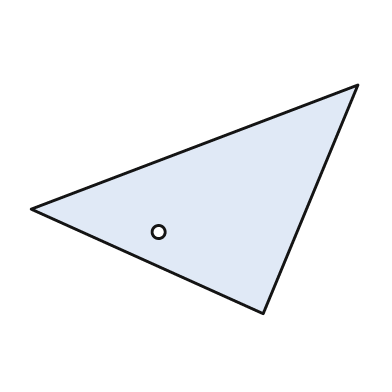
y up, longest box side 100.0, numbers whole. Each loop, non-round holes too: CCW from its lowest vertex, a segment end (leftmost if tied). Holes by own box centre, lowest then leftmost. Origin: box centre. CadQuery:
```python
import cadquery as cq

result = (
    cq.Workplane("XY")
    .moveTo(21.0, -35.0)
    .lineTo(50.0, 35.0)
    .lineTo(-50.0, -3.0)
    .close()
    .moveTo(-11.0, -10.0)
    .circle(2.0)
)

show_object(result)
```